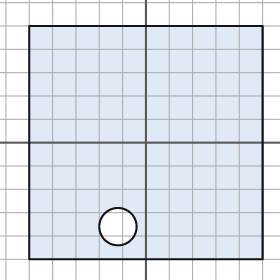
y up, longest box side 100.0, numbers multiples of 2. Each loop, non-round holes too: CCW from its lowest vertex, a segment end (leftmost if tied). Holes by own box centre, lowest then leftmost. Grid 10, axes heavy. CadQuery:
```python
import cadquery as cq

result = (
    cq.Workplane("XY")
    .moveTo(-50.0, -50.0)
    .lineTo(50.0, -50.0)
    .lineTo(50.0, 50.0)
    .lineTo(-50.0, 50.0)
    .close()
    .moveTo(-12.0, -36.0)
    .circle(8.0)
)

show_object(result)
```